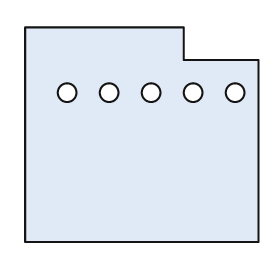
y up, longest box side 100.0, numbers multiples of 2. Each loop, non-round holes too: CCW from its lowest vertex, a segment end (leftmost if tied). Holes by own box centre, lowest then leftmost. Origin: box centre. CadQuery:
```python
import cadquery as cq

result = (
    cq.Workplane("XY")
    .moveTo(-50.0, -46.0)
    .lineTo(50.0, -46.0)
    .lineTo(50.0, 32.0)
    .lineTo(18.0, 32.0)
    .lineTo(18.0, 46.0)
    .lineTo(-50.0, 46.0)
    .close()
    .moveTo(-32.0, 18.0)
    .circle(4.0)
    .moveTo(-14.0, 18.0)
    .circle(4.0)
    .moveTo(4.0, 18.0)
    .circle(4.0)
    .moveTo(22.0, 18.0)
    .circle(4.0)
    .moveTo(40.0, 18.0)
    .circle(4.0)
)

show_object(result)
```